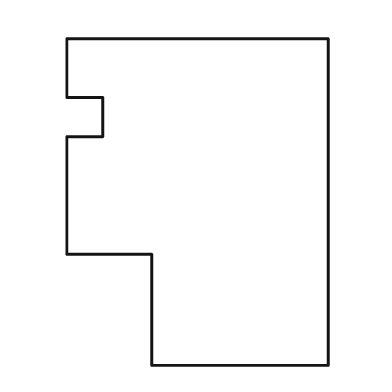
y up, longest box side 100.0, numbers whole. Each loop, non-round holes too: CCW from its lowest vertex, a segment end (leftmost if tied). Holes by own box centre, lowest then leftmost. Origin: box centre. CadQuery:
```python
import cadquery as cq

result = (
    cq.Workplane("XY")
    .moveTo(-14.0, -50.0)
    .lineTo(40.0, -50.0)
    .lineTo(40.0, 50.0)
    .lineTo(-40.0, 50.0)
    .lineTo(-40.0, 32.0)
    .lineTo(-29.0, 32.0)
    .lineTo(-29.0, 20.0)
    .lineTo(-40.0, 20.0)
    .lineTo(-40.0, -16.0)
    .lineTo(-14.0, -16.0)
    .close()
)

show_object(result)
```